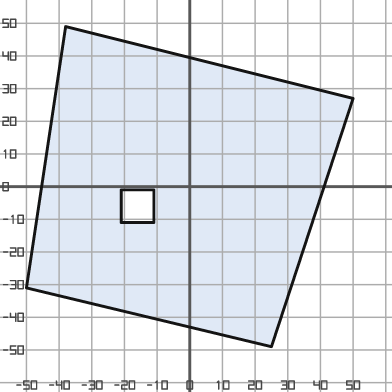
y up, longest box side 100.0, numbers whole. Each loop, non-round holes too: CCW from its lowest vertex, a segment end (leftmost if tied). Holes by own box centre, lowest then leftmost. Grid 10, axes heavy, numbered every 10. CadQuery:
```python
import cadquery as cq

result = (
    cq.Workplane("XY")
    .moveTo(25.0, -49.0)
    .lineTo(50.0, 27.0)
    .lineTo(-38.0, 49.0)
    .lineTo(-50.0, -31.0)
    .close()
    .moveTo(-21.0, -11.0)
    .lineTo(-11.0, -11.0)
    .lineTo(-11.0, -1.0)
    .lineTo(-21.0, -1.0)
    .close()
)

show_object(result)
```